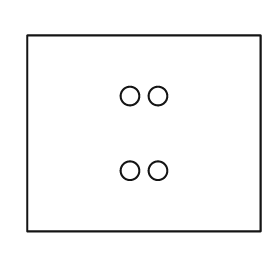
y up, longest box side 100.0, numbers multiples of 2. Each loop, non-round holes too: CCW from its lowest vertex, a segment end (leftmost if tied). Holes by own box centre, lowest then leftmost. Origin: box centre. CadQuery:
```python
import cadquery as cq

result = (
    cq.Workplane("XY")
    .moveTo(-50.0, -42.0)
    .lineTo(50.0, -42.0)
    .lineTo(50.0, 42.0)
    .lineTo(-50.0, 42.0)
    .close()
    .moveTo(-6.0, -16.0)
    .circle(4.0)
    .moveTo(6.0, -16.0)
    .circle(4.0)
    .moveTo(-6.0, 16.0)
    .circle(4.0)
    .moveTo(6.0, 16.0)
    .circle(4.0)
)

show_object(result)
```